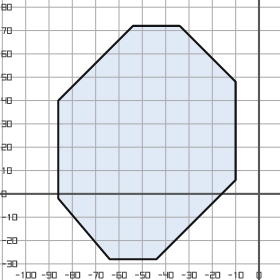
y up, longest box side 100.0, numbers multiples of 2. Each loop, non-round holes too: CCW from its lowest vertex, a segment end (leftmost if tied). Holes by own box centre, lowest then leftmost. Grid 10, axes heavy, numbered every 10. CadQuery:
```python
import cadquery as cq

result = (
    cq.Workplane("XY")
    .moveTo(-64.0, -28.0)
    .lineTo(-44.0, -28.0)
    .lineTo(-10.0, 6.0)
    .lineTo(-10.0, 48.0)
    .lineTo(-34.0, 72.0)
    .lineTo(-54.0, 72.0)
    .lineTo(-86.0, 40.0)
    .lineTo(-86.0, -2.0)
    .close()
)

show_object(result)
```